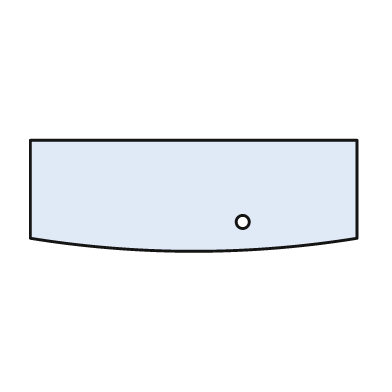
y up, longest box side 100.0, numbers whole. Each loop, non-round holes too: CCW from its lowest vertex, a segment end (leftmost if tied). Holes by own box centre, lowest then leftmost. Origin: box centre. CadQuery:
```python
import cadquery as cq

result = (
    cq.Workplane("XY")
    .moveTo(-50.0, -13.0)
    .threePointArc((0.0, -17.0), (50.0, -13.0))
    .lineTo(50.0, 17.0)
    .lineTo(-50.0, 17.0)
    .close()
    .moveTo(15.0, -8.0)
    .circle(2.0)
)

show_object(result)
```